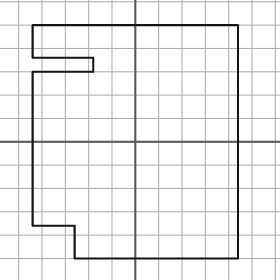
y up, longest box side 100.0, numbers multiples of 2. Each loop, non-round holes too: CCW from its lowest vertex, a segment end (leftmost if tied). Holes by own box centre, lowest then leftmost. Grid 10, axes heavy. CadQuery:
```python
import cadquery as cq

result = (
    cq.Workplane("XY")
    .moveTo(-26.0, -50.0)
    .lineTo(44.0, -50.0)
    .lineTo(44.0, 50.0)
    .lineTo(-44.0, 50.0)
    .lineTo(-44.0, 36.0)
    .lineTo(-18.0, 36.0)
    .lineTo(-18.0, 30.0)
    .lineTo(-44.0, 30.0)
    .lineTo(-44.0, -36.0)
    .lineTo(-26.0, -36.0)
    .close()
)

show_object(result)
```